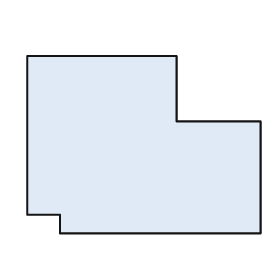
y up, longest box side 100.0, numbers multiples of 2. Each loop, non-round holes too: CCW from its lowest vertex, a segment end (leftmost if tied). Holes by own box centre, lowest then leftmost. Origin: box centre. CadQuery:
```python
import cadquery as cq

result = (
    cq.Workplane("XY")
    .moveTo(-36.0, -38.0)
    .lineTo(50.0, -38.0)
    .lineTo(50.0, 10.0)
    .lineTo(14.0, 10.0)
    .lineTo(14.0, 38.0)
    .lineTo(-50.0, 38.0)
    .lineTo(-50.0, -30.0)
    .lineTo(-36.0, -30.0)
    .close()
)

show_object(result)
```